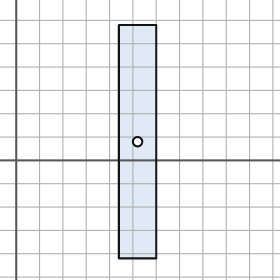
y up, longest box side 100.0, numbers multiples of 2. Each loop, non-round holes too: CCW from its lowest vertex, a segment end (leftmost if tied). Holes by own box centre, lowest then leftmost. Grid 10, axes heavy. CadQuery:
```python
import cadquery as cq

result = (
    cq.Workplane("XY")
    .moveTo(44.0, -42.0)
    .lineTo(60.0, -42.0)
    .lineTo(60.0, 58.0)
    .lineTo(44.0, 58.0)
    .close()
    .moveTo(52.0, 8.0)
    .circle(2.0)
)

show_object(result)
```